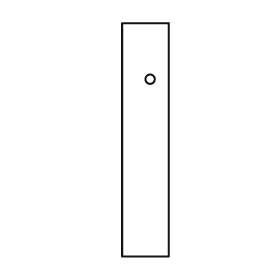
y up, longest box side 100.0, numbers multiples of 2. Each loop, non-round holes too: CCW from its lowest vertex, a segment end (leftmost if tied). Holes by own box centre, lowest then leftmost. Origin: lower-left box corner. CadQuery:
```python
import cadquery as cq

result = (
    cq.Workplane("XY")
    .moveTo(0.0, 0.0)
    .lineTo(20.0, 0.0)
    .lineTo(20.0, 100.0)
    .lineTo(0.0, 100.0)
    .close()
    .moveTo(12.0, 76.0)
    .circle(2.0)
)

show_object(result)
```